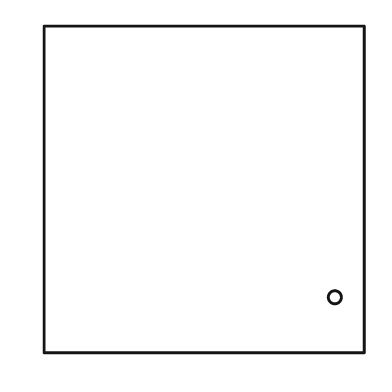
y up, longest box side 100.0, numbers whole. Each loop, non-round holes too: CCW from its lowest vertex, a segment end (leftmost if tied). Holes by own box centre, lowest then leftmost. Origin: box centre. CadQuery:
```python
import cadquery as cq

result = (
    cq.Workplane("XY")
    .moveTo(-49.0, -50.0)
    .lineTo(49.0, -50.0)
    .lineTo(49.0, 50.0)
    .lineTo(-49.0, 50.0)
    .close()
    .moveTo(40.0, -33.0)
    .circle(2.0)
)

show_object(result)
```